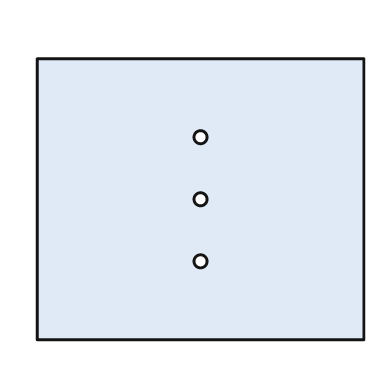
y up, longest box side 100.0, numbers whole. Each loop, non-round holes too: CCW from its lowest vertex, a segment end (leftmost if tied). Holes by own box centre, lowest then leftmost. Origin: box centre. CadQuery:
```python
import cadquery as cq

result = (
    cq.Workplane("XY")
    .moveTo(-50.0, -43.0)
    .lineTo(50.0, -43.0)
    .lineTo(50.0, 43.0)
    .lineTo(-50.0, 43.0)
    .close()
    .moveTo(0.0, -19.0)
    .circle(2.0)
    .moveTo(0.0, 0.0)
    .circle(2.0)
    .moveTo(0.0, 19.0)
    .circle(2.0)
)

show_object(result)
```